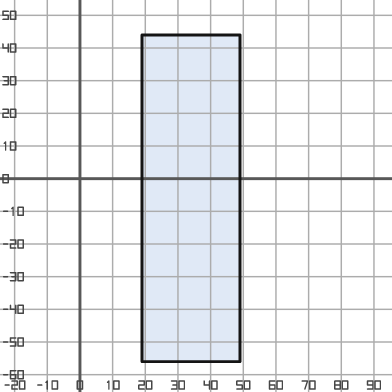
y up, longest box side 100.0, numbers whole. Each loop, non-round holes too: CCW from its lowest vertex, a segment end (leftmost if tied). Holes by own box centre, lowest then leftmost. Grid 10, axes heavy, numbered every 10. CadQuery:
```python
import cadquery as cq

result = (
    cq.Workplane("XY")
    .moveTo(19.0, -56.0)
    .lineTo(49.0, -56.0)
    .lineTo(49.0, 44.0)
    .lineTo(19.0, 44.0)
    .close()
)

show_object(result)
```